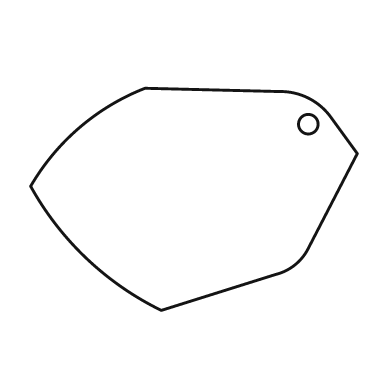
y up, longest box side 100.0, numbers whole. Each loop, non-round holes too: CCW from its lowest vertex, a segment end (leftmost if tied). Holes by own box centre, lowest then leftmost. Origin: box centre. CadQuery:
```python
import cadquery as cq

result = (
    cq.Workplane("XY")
    .moveTo(-10.0, -34.0)
    .lineTo(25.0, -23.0)
    .threePointArc((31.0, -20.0), (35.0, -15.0))
    .lineTo(50.0, 14.0)
    .lineTo(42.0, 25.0)
    .threePointArc((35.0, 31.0), (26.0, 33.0))
    .lineTo(-15.0, 34.0)
    .threePointArc((-35.0, 22.0), (-50.0, 4.0))
    .threePointArc((-33.0, -18.0), (-10.0, -34.0))
    .close()
    .moveTo(35.0, 23.0)
    .circle(3.0)
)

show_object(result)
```